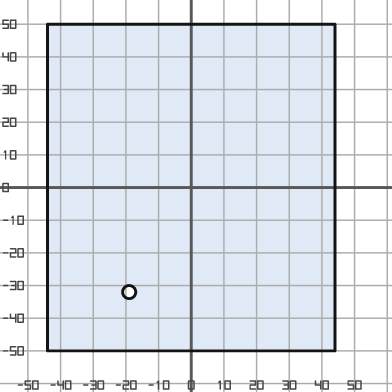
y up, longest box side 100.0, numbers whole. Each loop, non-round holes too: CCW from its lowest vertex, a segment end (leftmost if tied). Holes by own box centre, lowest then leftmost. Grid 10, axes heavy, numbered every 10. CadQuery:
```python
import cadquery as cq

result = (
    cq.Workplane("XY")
    .moveTo(-44.0, -50.0)
    .lineTo(44.0, -50.0)
    .lineTo(44.0, 50.0)
    .lineTo(-44.0, 50.0)
    .close()
    .moveTo(-19.0, -32.0)
    .circle(2.0)
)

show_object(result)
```